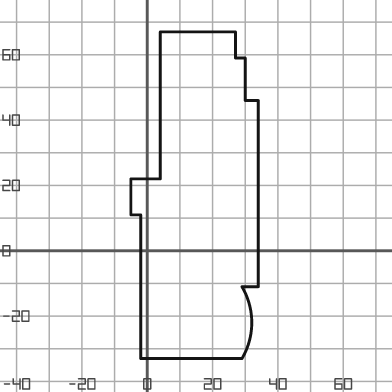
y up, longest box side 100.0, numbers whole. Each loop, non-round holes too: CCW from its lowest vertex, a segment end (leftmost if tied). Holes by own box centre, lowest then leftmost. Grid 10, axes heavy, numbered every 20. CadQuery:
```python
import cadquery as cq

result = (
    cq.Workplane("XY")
    .moveTo(-2.0, -33.0)
    .lineTo(29.0, -33.0)
    .threePointArc((32.0, -22.0), (29.0, -11.0))
    .lineTo(34.0, -11.0)
    .lineTo(34.0, 46.0)
    .lineTo(30.0, 46.0)
    .lineTo(30.0, 59.0)
    .lineTo(27.0, 59.0)
    .lineTo(27.0, 67.0)
    .lineTo(4.0, 67.0)
    .lineTo(4.0, 22.0)
    .lineTo(-5.0, 22.0)
    .lineTo(-5.0, 11.0)
    .lineTo(-2.0, 11.0)
    .close()
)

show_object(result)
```